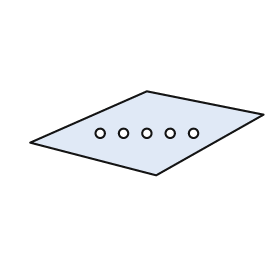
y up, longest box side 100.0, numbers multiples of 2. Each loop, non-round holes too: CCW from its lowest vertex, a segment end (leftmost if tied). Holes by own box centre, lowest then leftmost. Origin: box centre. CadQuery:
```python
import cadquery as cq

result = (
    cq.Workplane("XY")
    .moveTo(4.0, -18.0)
    .lineTo(50.0, 8.0)
    .lineTo(0.0, 18.0)
    .lineTo(-50.0, -4.0)
    .close()
    .moveTo(-20.0, 0.0)
    .circle(2.0)
    .moveTo(-10.0, 0.0)
    .circle(2.0)
    .moveTo(0.0, 0.0)
    .circle(2.0)
    .moveTo(10.0, 0.0)
    .circle(2.0)
    .moveTo(20.0, 0.0)
    .circle(2.0)
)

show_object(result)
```